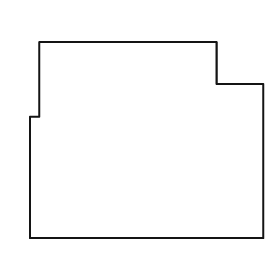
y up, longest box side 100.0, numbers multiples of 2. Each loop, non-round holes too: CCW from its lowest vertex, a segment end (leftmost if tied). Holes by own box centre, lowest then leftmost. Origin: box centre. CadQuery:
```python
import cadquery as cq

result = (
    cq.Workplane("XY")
    .moveTo(-50.0, -42.0)
    .lineTo(50.0, -42.0)
    .lineTo(50.0, 24.0)
    .lineTo(30.0, 24.0)
    .lineTo(30.0, 42.0)
    .lineTo(-46.0, 42.0)
    .lineTo(-46.0, 10.0)
    .lineTo(-50.0, 10.0)
    .close()
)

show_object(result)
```